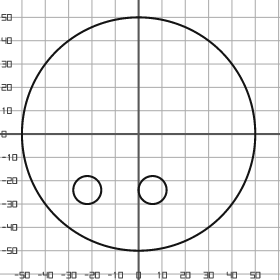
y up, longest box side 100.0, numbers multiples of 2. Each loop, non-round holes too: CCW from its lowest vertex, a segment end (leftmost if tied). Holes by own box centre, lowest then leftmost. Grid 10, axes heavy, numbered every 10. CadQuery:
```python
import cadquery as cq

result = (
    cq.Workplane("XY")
    .moveTo(0.0, 0.0)
    .circle(50.0)
    .moveTo(-22.0, -24.0)
    .circle(6.0)
    .moveTo(6.0, -24.0)
    .circle(6.0)
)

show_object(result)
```